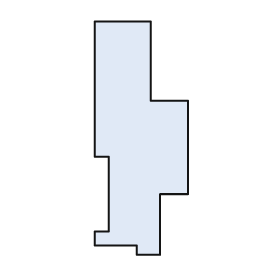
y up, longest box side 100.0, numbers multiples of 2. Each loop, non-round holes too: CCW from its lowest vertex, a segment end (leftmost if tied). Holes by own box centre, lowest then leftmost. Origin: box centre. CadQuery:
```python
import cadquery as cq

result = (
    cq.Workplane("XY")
    .moveTo(-2.0, -50.0)
    .lineTo(8.0, -50.0)
    .lineTo(8.0, -24.0)
    .lineTo(20.0, -24.0)
    .lineTo(20.0, 16.0)
    .lineTo(4.0, 16.0)
    .lineTo(4.0, 50.0)
    .lineTo(-20.0, 50.0)
    .lineTo(-20.0, -8.0)
    .lineTo(-14.0, -8.0)
    .lineTo(-14.0, -40.0)
    .lineTo(-20.0, -40.0)
    .lineTo(-20.0, -46.0)
    .lineTo(-2.0, -46.0)
    .close()
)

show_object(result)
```